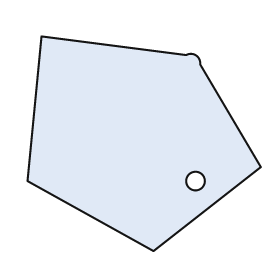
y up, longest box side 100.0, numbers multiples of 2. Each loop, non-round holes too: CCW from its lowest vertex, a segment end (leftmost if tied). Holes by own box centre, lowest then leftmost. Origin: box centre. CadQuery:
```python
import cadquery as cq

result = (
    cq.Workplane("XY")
    .moveTo(4.0, -46.0)
    .lineTo(50.0, -10.0)
    .lineTo(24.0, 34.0)
    .threePointArc((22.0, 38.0), (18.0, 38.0))
    .lineTo(-44.0, 46.0)
    .lineTo(-50.0, -16.0)
    .close()
    .moveTo(22.0, -16.0)
    .circle(4.0)
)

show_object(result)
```